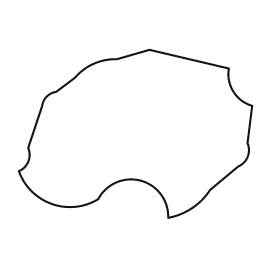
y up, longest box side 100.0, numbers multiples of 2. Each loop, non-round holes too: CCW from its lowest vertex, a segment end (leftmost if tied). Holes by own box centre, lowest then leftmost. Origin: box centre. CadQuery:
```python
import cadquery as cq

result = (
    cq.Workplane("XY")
    .moveTo(14.0, -36.0)
    .threePointArc((24.0, -32.0), (32.0, -24.0))
    .lineTo(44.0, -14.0)
    .threePointArc((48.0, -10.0), (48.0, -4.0))
    .lineTo(50.0, 12.0)
    .threePointArc((42.0, 18.0), (40.0, 28.0))
    .lineTo(6.0, 36.0)
    .lineTo(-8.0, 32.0)
    .threePointArc((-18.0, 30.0), (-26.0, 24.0))
    .lineTo(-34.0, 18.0)
    .threePointArc((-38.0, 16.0), (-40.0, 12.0))
    .lineTo(-46.0, -6.0)
    .threePointArc((-46.0, -12.0), (-50.0, -16.0))
    .threePointArc((-36.0, -30.0), (-16.0, -28.0))
    .threePointArc((2.0, -20.0), (14.0, -36.0))
    .close()
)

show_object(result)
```